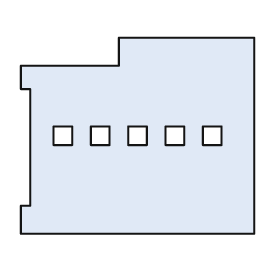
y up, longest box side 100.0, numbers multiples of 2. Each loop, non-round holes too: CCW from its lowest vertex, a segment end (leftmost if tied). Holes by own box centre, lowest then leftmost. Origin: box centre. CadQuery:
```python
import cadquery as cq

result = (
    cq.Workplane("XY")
    .moveTo(-50.0, -42.0)
    .lineTo(50.0, -42.0)
    .lineTo(50.0, 42.0)
    .lineTo(-8.0, 42.0)
    .lineTo(-8.0, 30.0)
    .lineTo(-50.0, 30.0)
    .lineTo(-50.0, 20.0)
    .lineTo(-46.0, 20.0)
    .lineTo(-46.0, -30.0)
    .lineTo(-50.0, -30.0)
    .close()
    .moveTo(-36.0, -4.0)
    .lineTo(-28.0, -4.0)
    .lineTo(-28.0, 4.0)
    .lineTo(-36.0, 4.0)
    .close()
    .moveTo(-20.0, -4.0)
    .lineTo(-12.0, -4.0)
    .lineTo(-12.0, 4.0)
    .lineTo(-20.0, 4.0)
    .close()
    .moveTo(-4.0, -4.0)
    .lineTo(4.0, -4.0)
    .lineTo(4.0, 4.0)
    .lineTo(-4.0, 4.0)
    .close()
    .moveTo(12.0, -4.0)
    .lineTo(20.0, -4.0)
    .lineTo(20.0, 4.0)
    .lineTo(12.0, 4.0)
    .close()
    .moveTo(28.0, -4.0)
    .lineTo(36.0, -4.0)
    .lineTo(36.0, 4.0)
    .lineTo(28.0, 4.0)
    .close()
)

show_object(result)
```